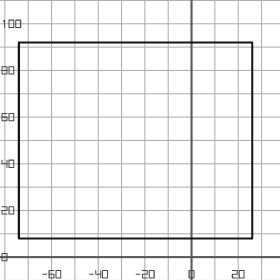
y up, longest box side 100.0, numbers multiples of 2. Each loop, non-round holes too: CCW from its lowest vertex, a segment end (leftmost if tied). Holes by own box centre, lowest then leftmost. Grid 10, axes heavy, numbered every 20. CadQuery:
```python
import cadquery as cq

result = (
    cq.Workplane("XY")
    .moveTo(-74.0, 8.0)
    .lineTo(26.0, 8.0)
    .lineTo(26.0, 92.0)
    .lineTo(-74.0, 92.0)
    .close()
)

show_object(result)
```